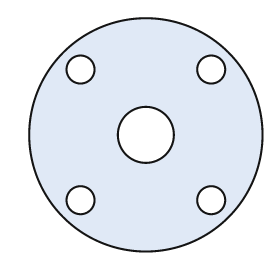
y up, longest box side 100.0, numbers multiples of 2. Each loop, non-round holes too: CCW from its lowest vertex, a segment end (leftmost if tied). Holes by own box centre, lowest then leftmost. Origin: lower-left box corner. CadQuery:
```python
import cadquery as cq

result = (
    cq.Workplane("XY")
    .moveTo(50.0, 50.0)
    .circle(50.0)
    .moveTo(22.0, 22.0)
    .circle(6.0)
    .moveTo(78.0, 22.0)
    .circle(6.0)
    .moveTo(50.0, 50.0)
    .circle(12.0)
    .moveTo(22.0, 78.0)
    .circle(6.0)
    .moveTo(78.0, 78.0)
    .circle(6.0)
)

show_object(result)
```